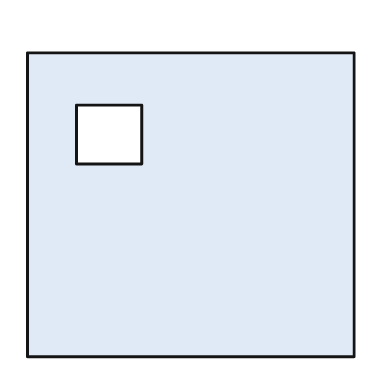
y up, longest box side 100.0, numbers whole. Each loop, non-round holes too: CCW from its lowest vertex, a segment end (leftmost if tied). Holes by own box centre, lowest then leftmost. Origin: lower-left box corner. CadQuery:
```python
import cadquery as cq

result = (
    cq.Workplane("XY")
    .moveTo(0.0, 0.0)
    .lineTo(100.0, 0.0)
    .lineTo(100.0, 93.0)
    .lineTo(0.0, 93.0)
    .close()
    .moveTo(15.0, 59.0)
    .lineTo(35.0, 59.0)
    .lineTo(35.0, 77.0)
    .lineTo(15.0, 77.0)
    .close()
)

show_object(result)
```